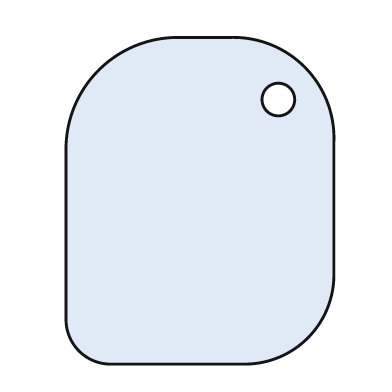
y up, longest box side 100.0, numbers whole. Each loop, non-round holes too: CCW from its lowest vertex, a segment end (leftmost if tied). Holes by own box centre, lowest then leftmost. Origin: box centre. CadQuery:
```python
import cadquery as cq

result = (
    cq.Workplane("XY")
    .moveTo(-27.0, -50.0)
    .lineTo(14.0, -50.0)
    .threePointArc((33.0, -42.0), (41.0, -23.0))
    .lineTo(41.0, 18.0)
    .threePointArc((32.0, 41.0), (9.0, 50.0))
    .lineTo(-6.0, 50.0)
    .threePointArc((-31.0, 40.0), (-41.0, 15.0))
    .lineTo(-41.0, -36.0)
    .threePointArc((-37.0, -46.0), (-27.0, -50.0))
    .close()
    .moveTo(24.0, 31.0)
    .circle(5.0)
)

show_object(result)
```